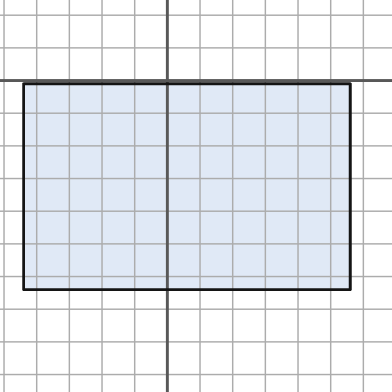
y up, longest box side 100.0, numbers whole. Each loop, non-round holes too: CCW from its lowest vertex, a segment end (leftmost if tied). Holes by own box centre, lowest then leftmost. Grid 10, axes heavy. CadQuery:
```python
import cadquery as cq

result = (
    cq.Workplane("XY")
    .moveTo(-44.0, -64.0)
    .lineTo(56.0, -64.0)
    .lineTo(56.0, -1.0)
    .lineTo(-44.0, -1.0)
    .close()
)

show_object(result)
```